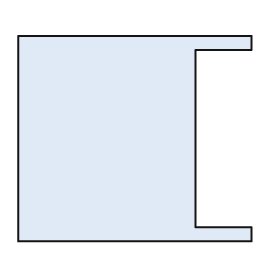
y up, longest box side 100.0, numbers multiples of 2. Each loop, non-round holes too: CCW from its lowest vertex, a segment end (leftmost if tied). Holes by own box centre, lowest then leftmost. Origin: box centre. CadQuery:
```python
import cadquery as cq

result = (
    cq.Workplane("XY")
    .moveTo(-50.0, -44.0)
    .lineTo(50.0, -44.0)
    .lineTo(50.0, -38.0)
    .lineTo(26.0, -38.0)
    .lineTo(26.0, 38.0)
    .lineTo(50.0, 38.0)
    .lineTo(50.0, 44.0)
    .lineTo(-50.0, 44.0)
    .close()
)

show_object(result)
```